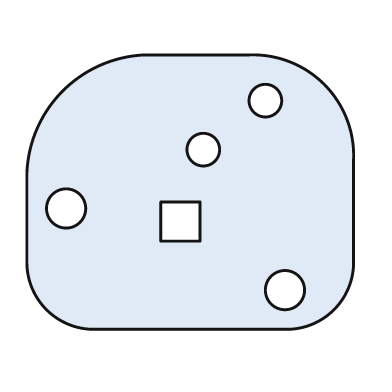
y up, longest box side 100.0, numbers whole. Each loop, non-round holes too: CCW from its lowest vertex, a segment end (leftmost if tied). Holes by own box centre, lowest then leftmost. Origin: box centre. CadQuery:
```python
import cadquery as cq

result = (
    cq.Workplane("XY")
    .moveTo(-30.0, -42.0)
    .lineTo(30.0, -42.0)
    .threePointArc((44.0, -36.0), (50.0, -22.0))
    .lineTo(50.0, 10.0)
    .threePointArc((41.0, 33.0), (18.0, 42.0))
    .lineTo(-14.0, 42.0)
    .threePointArc((-39.0, 31.0), (-50.0, 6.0))
    .lineTo(-50.0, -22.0)
    .threePointArc((-44.0, -36.0), (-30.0, -42.0))
    .close()
    .moveTo(29.0, -30.0)
    .circle(6.0)
    .moveTo(-9.0, -15.0)
    .lineTo(3.0, -15.0)
    .lineTo(3.0, -3.0)
    .lineTo(-9.0, -3.0)
    .close()
    .moveTo(-38.0, -5.0)
    .circle(6.0)
    .moveTo(4.0, 13.0)
    .circle(5.0)
    .moveTo(23.0, 28.0)
    .circle(5.0)
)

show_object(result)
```